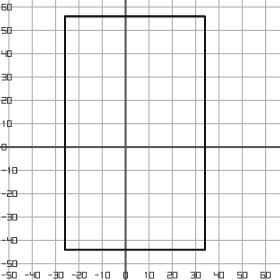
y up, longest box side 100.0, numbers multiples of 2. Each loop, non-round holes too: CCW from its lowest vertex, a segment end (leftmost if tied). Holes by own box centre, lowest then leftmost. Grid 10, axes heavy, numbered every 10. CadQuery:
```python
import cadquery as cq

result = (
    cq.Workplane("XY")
    .moveTo(-26.0, -44.0)
    .lineTo(34.0, -44.0)
    .lineTo(34.0, 56.0)
    .lineTo(-26.0, 56.0)
    .close()
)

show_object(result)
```